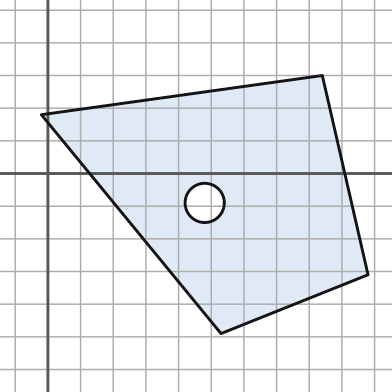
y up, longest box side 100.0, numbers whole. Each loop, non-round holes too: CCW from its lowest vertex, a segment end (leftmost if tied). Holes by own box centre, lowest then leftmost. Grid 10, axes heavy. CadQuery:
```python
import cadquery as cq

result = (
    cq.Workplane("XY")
    .moveTo(53.0, -49.0)
    .lineTo(98.0, -31.0)
    .lineTo(84.0, 30.0)
    .lineTo(-2.0, 18.0)
    .close()
    .moveTo(48.0, -9.0)
    .circle(6.0)
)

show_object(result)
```